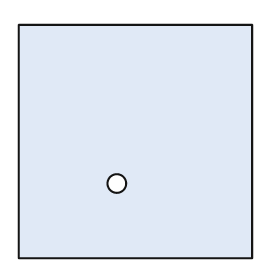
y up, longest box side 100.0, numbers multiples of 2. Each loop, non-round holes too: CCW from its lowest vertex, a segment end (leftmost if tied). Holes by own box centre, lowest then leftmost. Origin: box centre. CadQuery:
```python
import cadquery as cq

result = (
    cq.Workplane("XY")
    .moveTo(-50.0, -50.0)
    .lineTo(50.0, -50.0)
    .lineTo(50.0, 50.0)
    .lineTo(-50.0, 50.0)
    .close()
    .moveTo(-8.0, -18.0)
    .circle(4.0)
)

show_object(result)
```